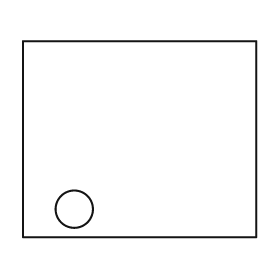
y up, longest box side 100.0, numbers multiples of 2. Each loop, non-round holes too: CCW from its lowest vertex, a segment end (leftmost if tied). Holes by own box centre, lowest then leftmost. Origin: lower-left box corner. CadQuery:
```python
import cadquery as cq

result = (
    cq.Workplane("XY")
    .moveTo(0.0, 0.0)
    .lineTo(100.0, 0.0)
    .lineTo(100.0, 84.0)
    .lineTo(0.0, 84.0)
    .close()
    .moveTo(22.0, 12.0)
    .circle(8.0)
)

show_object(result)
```